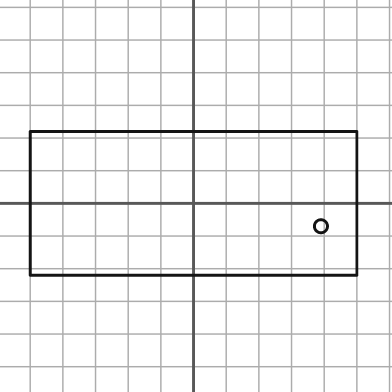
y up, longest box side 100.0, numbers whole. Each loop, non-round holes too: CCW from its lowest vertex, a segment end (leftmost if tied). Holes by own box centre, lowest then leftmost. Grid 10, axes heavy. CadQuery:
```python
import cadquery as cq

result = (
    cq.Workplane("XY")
    .moveTo(-50.0, -22.0)
    .lineTo(50.0, -22.0)
    .lineTo(50.0, 22.0)
    .lineTo(-50.0, 22.0)
    .close()
    .moveTo(39.0, -7.0)
    .circle(2.0)
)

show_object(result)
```